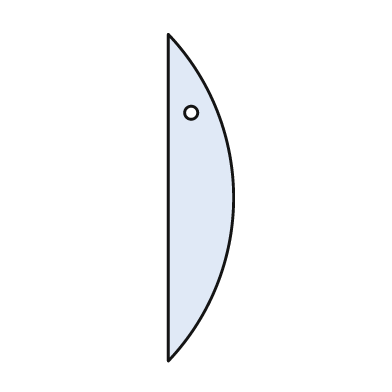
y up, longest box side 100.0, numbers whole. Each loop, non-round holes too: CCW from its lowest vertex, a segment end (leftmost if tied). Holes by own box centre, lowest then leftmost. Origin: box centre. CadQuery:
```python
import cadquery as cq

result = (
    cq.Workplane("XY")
    .moveTo(-10.0, -50.0)
    .threePointArc((10.0, 0.0), (-10.0, 50.0))
    .close()
    .moveTo(-3.0, 26.0)
    .circle(2.0)
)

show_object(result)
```